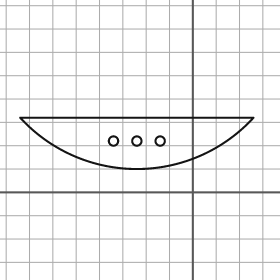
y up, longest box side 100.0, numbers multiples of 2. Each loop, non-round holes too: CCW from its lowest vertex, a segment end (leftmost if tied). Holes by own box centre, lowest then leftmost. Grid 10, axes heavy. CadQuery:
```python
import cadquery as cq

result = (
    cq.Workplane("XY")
    .moveTo(-74.0, 32.0)
    .threePointArc((-24.0, 10.0), (26.0, 32.0))
    .close()
    .moveTo(-34.0, 22.0)
    .circle(2.0)
    .moveTo(-24.0, 22.0)
    .circle(2.0)
    .moveTo(-14.0, 22.0)
    .circle(2.0)
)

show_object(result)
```